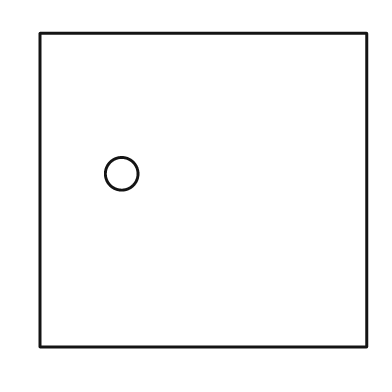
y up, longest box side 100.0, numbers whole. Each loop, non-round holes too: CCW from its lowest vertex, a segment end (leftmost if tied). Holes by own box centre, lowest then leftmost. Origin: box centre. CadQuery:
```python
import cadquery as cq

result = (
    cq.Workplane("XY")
    .moveTo(-50.0, -48.0)
    .lineTo(50.0, -48.0)
    .lineTo(50.0, 48.0)
    .lineTo(-50.0, 48.0)
    .close()
    .moveTo(-25.0, 5.0)
    .circle(5.0)
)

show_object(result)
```